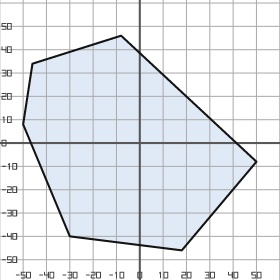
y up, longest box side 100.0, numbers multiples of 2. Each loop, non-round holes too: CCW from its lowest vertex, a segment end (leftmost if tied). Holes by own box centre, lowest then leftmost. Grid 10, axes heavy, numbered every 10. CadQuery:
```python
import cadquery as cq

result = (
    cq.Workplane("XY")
    .moveTo(18.0, -46.0)
    .lineTo(50.0, -8.0)
    .lineTo(-8.0, 46.0)
    .lineTo(-46.0, 34.0)
    .lineTo(-50.0, 8.0)
    .lineTo(-30.0, -40.0)
    .close()
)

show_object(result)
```